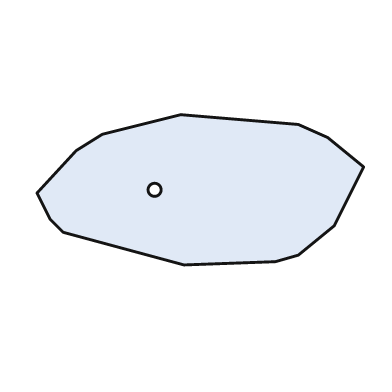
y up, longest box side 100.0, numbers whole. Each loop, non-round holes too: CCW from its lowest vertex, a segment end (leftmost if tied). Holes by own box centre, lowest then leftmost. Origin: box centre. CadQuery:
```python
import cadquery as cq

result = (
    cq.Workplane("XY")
    .moveTo(-5.0, -23.0)
    .lineTo(23.0, -22.0)
    .lineTo(30.0, -20.0)
    .lineTo(41.0, -11.0)
    .lineTo(50.0, 7.0)
    .lineTo(39.0, 16.0)
    .lineTo(30.0, 20.0)
    .lineTo(-6.0, 23.0)
    .lineTo(-30.0, 17.0)
    .lineTo(-38.0, 12.0)
    .lineTo(-50.0, -1.0)
    .lineTo(-46.0, -9.0)
    .lineTo(-42.0, -13.0)
    .close()
    .moveTo(-14.0, 0.0)
    .circle(2.0)
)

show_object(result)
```